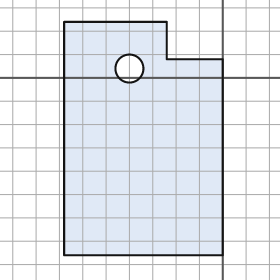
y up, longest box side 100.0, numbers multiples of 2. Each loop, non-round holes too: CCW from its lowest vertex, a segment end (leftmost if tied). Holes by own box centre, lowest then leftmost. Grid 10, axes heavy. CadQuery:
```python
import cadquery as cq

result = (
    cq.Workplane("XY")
    .moveTo(-68.0, -76.0)
    .lineTo(0.0, -76.0)
    .lineTo(0.0, 8.0)
    .lineTo(-24.0, 8.0)
    .lineTo(-24.0, 24.0)
    .lineTo(-68.0, 24.0)
    .close()
    .moveTo(-40.0, 4.0)
    .circle(6.0)
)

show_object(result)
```